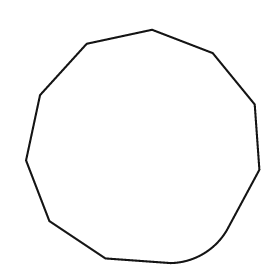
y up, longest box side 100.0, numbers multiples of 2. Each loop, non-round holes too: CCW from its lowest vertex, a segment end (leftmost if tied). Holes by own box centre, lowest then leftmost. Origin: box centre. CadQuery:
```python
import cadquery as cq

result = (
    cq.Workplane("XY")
    .moveTo(12.0, -50.0)
    .threePointArc((26.0, -46.0), (36.0, -36.0))
    .lineTo(50.0, -10.0)
    .lineTo(48.0, 18.0)
    .lineTo(30.0, 40.0)
    .lineTo(4.0, 50.0)
    .lineTo(-24.0, 44.0)
    .lineTo(-44.0, 22.0)
    .lineTo(-50.0, -6.0)
    .lineTo(-40.0, -32.0)
    .lineTo(-16.0, -48.0)
    .close()
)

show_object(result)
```